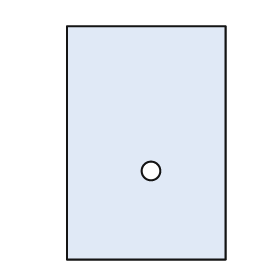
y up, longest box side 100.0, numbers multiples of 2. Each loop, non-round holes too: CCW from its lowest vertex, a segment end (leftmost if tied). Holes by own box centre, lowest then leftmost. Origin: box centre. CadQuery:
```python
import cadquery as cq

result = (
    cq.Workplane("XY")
    .moveTo(-34.0, -50.0)
    .lineTo(34.0, -50.0)
    .lineTo(34.0, 50.0)
    .lineTo(-34.0, 50.0)
    .close()
    .moveTo(2.0, -12.0)
    .circle(4.0)
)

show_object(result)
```